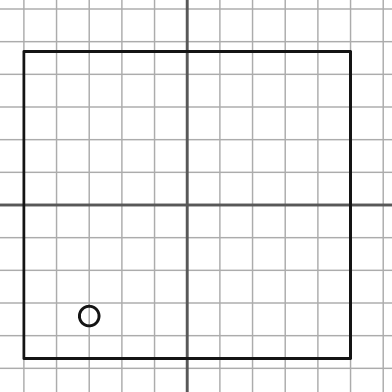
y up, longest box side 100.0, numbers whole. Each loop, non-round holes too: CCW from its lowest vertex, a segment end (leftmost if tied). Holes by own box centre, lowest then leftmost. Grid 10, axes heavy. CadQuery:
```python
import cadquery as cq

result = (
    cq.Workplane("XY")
    .moveTo(-50.0, -47.0)
    .lineTo(50.0, -47.0)
    .lineTo(50.0, 47.0)
    .lineTo(-50.0, 47.0)
    .close()
    .moveTo(-30.0, -34.0)
    .circle(3.0)
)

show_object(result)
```